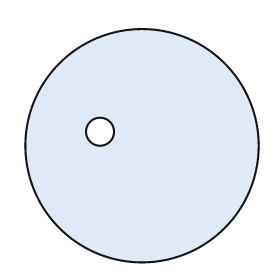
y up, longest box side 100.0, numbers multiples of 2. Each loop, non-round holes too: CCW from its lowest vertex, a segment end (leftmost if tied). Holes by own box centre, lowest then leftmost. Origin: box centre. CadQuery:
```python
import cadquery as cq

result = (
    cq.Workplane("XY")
    .moveTo(0.0, 0.0)
    .circle(50.0)
    .moveTo(-18.0, 6.0)
    .circle(6.0)
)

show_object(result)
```